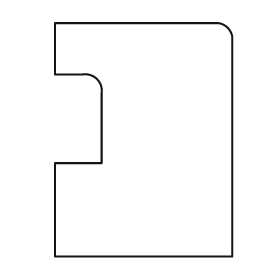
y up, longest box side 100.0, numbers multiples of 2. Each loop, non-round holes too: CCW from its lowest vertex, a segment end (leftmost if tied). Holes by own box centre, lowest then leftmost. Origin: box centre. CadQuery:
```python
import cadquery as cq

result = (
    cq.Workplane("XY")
    .moveTo(-38.0, -50.0)
    .lineTo(38.0, -50.0)
    .lineTo(38.0, 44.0)
    .threePointArc((36.0, 48.0), (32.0, 50.0))
    .lineTo(-38.0, 50.0)
    .lineTo(-38.0, 28.0)
    .lineTo(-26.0, 28.0)
    .threePointArc((-20.0, 26.0), (-18.0, 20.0))
    .lineTo(-18.0, -10.0)
    .lineTo(-38.0, -10.0)
    .close()
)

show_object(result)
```